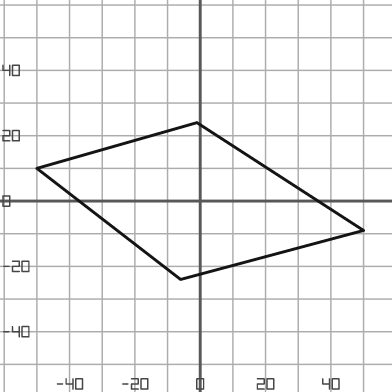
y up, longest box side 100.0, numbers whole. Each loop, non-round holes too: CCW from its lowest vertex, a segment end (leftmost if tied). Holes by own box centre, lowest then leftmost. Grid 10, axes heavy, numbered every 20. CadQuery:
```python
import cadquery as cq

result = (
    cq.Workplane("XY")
    .moveTo(-6.0, -24.0)
    .lineTo(50.0, -9.0)
    .lineTo(-1.0, 24.0)
    .lineTo(-50.0, 10.0)
    .close()
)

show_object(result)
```